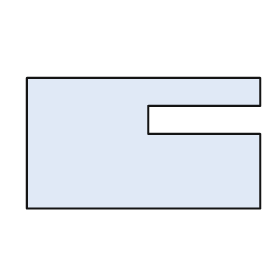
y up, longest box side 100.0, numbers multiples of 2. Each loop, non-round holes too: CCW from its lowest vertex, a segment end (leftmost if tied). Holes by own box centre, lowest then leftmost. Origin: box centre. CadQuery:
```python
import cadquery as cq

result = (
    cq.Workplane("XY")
    .moveTo(-50.0, -28.0)
    .lineTo(50.0, -28.0)
    .lineTo(50.0, 4.0)
    .lineTo(2.0, 4.0)
    .lineTo(2.0, 16.0)
    .lineTo(50.0, 16.0)
    .lineTo(50.0, 28.0)
    .lineTo(-50.0, 28.0)
    .close()
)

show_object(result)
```